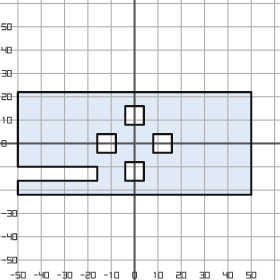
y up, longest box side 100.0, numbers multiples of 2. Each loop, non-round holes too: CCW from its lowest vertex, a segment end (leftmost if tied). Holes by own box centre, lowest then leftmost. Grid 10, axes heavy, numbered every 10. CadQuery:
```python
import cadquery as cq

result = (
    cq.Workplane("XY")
    .moveTo(-50.0, -22.0)
    .lineTo(50.0, -22.0)
    .lineTo(50.0, 22.0)
    .lineTo(-50.0, 22.0)
    .lineTo(-50.0, -10.0)
    .lineTo(-16.0, -10.0)
    .lineTo(-16.0, -16.0)
    .lineTo(-50.0, -16.0)
    .close()
    .moveTo(-4.0, -16.0)
    .lineTo(4.0, -16.0)
    .lineTo(4.0, -8.0)
    .lineTo(-4.0, -8.0)
    .close()
    .moveTo(-16.0, -4.0)
    .lineTo(-8.0, -4.0)
    .lineTo(-8.0, 4.0)
    .lineTo(-16.0, 4.0)
    .close()
    .moveTo(8.0, -4.0)
    .lineTo(16.0, -4.0)
    .lineTo(16.0, 4.0)
    .lineTo(8.0, 4.0)
    .close()
    .moveTo(-4.0, 8.0)
    .lineTo(4.0, 8.0)
    .lineTo(4.0, 16.0)
    .lineTo(-4.0, 16.0)
    .close()
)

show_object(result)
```